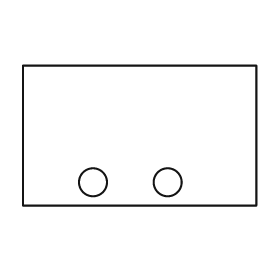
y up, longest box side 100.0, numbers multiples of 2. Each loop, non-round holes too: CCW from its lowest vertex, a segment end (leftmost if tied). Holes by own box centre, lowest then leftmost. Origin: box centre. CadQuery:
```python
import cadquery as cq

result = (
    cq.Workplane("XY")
    .moveTo(-50.0, -30.0)
    .lineTo(50.0, -30.0)
    .lineTo(50.0, 30.0)
    .lineTo(-50.0, 30.0)
    .close()
    .moveTo(-20.0, -20.0)
    .circle(6.0)
    .moveTo(12.0, -20.0)
    .circle(6.0)
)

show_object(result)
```